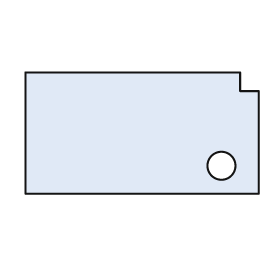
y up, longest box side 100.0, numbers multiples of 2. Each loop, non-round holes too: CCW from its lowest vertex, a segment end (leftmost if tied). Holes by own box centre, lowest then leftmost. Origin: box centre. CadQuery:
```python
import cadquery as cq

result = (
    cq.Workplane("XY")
    .moveTo(-50.0, -26.0)
    .lineTo(50.0, -26.0)
    .lineTo(50.0, 18.0)
    .lineTo(42.0, 18.0)
    .lineTo(42.0, 26.0)
    .lineTo(-50.0, 26.0)
    .close()
    .moveTo(34.0, -14.0)
    .circle(6.0)
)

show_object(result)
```